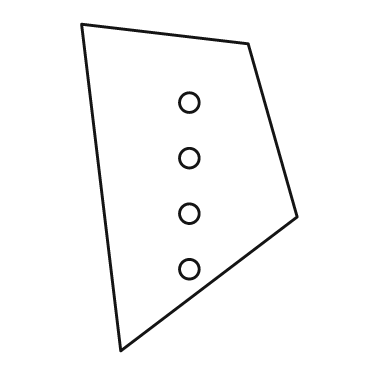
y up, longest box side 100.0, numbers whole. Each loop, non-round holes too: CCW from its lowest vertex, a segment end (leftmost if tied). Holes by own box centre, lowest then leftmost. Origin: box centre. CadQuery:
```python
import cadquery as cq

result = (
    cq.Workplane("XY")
    .moveTo(-21.0, -50.0)
    .lineTo(33.0, -9.0)
    .lineTo(18.0, 44.0)
    .lineTo(-33.0, 50.0)
    .close()
    .moveTo(0.0, -25.0)
    .circle(3.0)
    .moveTo(0.0, -8.0)
    .circle(3.0)
    .moveTo(0.0, 9.0)
    .circle(3.0)
    .moveTo(0.0, 26.0)
    .circle(3.0)
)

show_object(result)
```